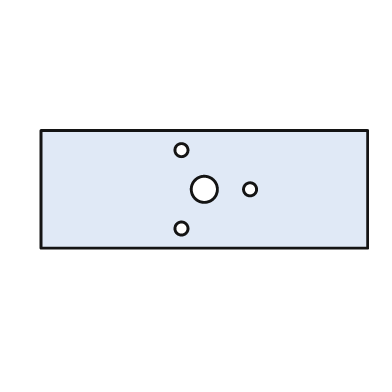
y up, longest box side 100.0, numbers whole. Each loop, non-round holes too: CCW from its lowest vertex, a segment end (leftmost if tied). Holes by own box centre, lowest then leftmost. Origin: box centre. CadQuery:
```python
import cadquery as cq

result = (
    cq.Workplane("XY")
    .moveTo(-50.0, -18.0)
    .lineTo(50.0, -18.0)
    .lineTo(50.0, 18.0)
    .lineTo(-50.0, 18.0)
    .close()
    .moveTo(-7.0, -12.0)
    .circle(2.0)
    .moveTo(0.0, 0.0)
    .circle(4.0)
    .moveTo(14.0, 0.0)
    .circle(2.0)
    .moveTo(-7.0, 12.0)
    .circle(2.0)
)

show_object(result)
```